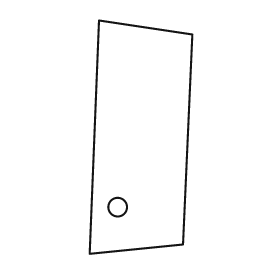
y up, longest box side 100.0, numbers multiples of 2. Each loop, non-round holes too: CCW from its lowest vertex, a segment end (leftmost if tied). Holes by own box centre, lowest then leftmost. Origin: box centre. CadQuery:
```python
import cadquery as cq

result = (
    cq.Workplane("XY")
    .moveTo(-22.0, -50.0)
    .lineTo(18.0, -46.0)
    .lineTo(22.0, 44.0)
    .lineTo(-18.0, 50.0)
    .close()
    .moveTo(-10.0, -30.0)
    .circle(4.0)
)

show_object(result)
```